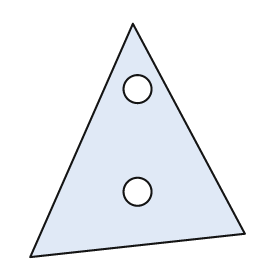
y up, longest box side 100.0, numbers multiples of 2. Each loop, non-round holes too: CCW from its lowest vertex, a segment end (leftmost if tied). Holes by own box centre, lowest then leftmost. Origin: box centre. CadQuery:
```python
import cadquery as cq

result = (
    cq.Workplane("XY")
    .moveTo(-46.0, -50.0)
    .lineTo(46.0, -40.0)
    .lineTo(-2.0, 50.0)
    .close()
    .moveTo(0.0, -22.0)
    .circle(6.0)
    .moveTo(0.0, 22.0)
    .circle(6.0)
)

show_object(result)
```